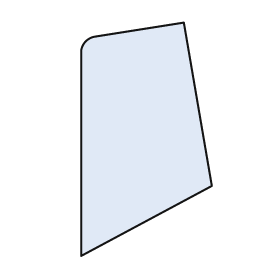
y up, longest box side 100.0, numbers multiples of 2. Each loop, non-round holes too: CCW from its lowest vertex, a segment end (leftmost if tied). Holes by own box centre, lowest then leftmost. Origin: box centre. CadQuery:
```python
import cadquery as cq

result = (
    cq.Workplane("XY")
    .moveTo(-28.0, -50.0)
    .lineTo(28.0, -20.0)
    .lineTo(16.0, 50.0)
    .lineTo(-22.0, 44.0)
    .threePointArc((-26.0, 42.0), (-28.0, 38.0))
    .close()
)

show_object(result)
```